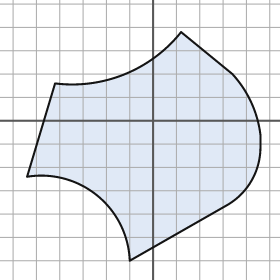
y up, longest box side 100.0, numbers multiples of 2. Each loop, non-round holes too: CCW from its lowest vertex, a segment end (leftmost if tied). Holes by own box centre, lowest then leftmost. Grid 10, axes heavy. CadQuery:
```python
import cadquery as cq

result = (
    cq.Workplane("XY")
    .moveTo(-10.0, -60.0)
    .lineTo(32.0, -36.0)
    .threePointArc((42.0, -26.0), (46.0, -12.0))
    .lineTo(46.0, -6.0)
    .threePointArc((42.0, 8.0), (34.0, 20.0))
    .lineTo(12.0, 38.0)
    .threePointArc((-12.0, 20.0), (-42.0, 16.0))
    .lineTo(-54.0, -24.0)
    .threePointArc((-24.0, -32.0), (-10.0, -60.0))
    .close()
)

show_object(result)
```